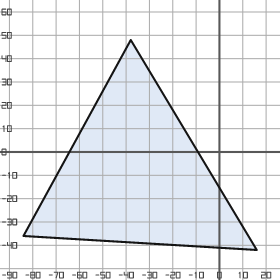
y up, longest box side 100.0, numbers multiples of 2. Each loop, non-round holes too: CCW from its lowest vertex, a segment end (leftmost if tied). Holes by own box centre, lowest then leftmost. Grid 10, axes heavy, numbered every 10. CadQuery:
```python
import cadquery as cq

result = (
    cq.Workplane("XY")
    .moveTo(16.0, -42.0)
    .lineTo(-38.0, 48.0)
    .lineTo(-84.0, -36.0)
    .close()
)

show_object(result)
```